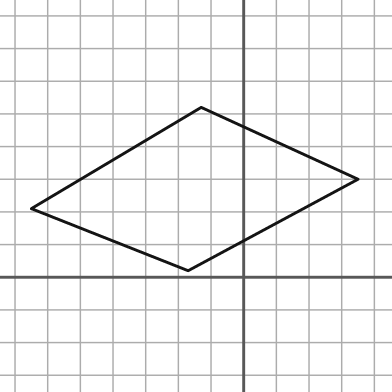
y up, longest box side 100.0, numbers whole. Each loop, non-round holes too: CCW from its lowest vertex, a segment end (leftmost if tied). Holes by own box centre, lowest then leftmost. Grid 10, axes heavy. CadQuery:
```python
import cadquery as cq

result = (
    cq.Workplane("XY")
    .moveTo(-17.0, 2.0)
    .lineTo(35.0, 30.0)
    .lineTo(-13.0, 52.0)
    .lineTo(-65.0, 21.0)
    .close()
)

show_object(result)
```